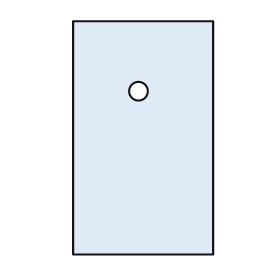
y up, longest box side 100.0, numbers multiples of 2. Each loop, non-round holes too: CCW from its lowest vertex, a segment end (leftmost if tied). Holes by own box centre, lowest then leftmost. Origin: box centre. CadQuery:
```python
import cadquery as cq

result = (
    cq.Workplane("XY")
    .moveTo(-30.0, -50.0)
    .lineTo(30.0, -50.0)
    .lineTo(30.0, 50.0)
    .lineTo(-30.0, 50.0)
    .close()
    .moveTo(-2.0, 20.0)
    .circle(4.0)
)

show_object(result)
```